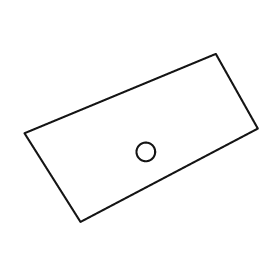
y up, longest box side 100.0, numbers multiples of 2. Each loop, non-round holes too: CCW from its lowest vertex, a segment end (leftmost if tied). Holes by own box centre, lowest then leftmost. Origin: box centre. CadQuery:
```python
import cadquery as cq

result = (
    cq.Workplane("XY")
    .moveTo(-26.0, -36.0)
    .lineTo(50.0, 4.0)
    .lineTo(32.0, 36.0)
    .lineTo(-50.0, 2.0)
    .close()
    .moveTo(2.0, -6.0)
    .circle(4.0)
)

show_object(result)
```